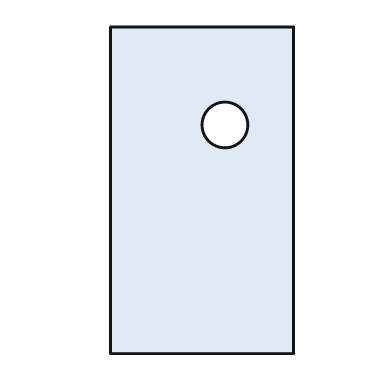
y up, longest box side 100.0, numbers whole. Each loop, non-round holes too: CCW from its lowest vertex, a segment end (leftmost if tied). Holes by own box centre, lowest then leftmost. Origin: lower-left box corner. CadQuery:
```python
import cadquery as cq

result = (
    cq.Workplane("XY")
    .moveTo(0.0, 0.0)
    .lineTo(56.0, 0.0)
    .lineTo(56.0, 100.0)
    .lineTo(0.0, 100.0)
    .close()
    .moveTo(35.0, 70.0)
    .circle(7.0)
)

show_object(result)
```